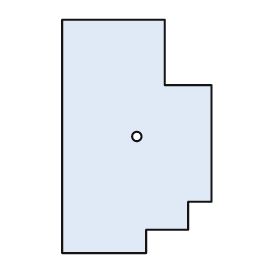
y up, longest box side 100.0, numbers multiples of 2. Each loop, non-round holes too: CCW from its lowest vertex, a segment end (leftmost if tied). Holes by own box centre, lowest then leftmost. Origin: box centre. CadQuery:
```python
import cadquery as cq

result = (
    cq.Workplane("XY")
    .moveTo(-32.0, -50.0)
    .lineTo(4.0, -50.0)
    .lineTo(4.0, -40.0)
    .lineTo(22.0, -40.0)
    .lineTo(22.0, -28.0)
    .lineTo(32.0, -28.0)
    .lineTo(32.0, 22.0)
    .lineTo(12.0, 22.0)
    .lineTo(12.0, 50.0)
    .lineTo(-32.0, 50.0)
    .close()
    .moveTo(0.0, 0.0)
    .circle(2.0)
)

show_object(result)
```